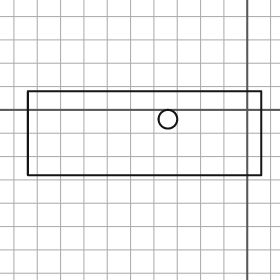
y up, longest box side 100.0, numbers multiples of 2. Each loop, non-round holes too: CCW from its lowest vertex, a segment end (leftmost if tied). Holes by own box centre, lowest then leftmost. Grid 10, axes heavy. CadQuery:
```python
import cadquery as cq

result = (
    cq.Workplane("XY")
    .moveTo(-94.0, -28.0)
    .lineTo(6.0, -28.0)
    .lineTo(6.0, 8.0)
    .lineTo(-94.0, 8.0)
    .close()
    .moveTo(-34.0, -4.0)
    .circle(4.0)
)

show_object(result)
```